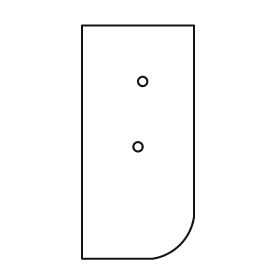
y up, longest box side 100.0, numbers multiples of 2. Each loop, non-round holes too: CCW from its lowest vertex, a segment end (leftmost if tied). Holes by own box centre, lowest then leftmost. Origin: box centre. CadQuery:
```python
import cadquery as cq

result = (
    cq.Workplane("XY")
    .moveTo(-24.0, -50.0)
    .lineTo(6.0, -50.0)
    .threePointArc((18.0, -44.0), (24.0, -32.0))
    .lineTo(24.0, 50.0)
    .lineTo(-24.0, 50.0)
    .close()
    .moveTo(0.0, -2.0)
    .circle(2.0)
    .moveTo(2.0, 26.0)
    .circle(2.0)
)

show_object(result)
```